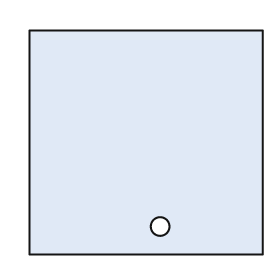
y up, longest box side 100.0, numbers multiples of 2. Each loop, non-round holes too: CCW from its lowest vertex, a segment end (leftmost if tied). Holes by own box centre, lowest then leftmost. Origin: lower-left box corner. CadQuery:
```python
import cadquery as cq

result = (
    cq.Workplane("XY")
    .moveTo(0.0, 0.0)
    .lineTo(100.0, 0.0)
    .lineTo(100.0, 96.0)
    .lineTo(0.0, 96.0)
    .close()
    .moveTo(56.0, 12.0)
    .circle(4.0)
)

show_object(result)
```